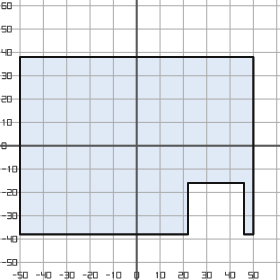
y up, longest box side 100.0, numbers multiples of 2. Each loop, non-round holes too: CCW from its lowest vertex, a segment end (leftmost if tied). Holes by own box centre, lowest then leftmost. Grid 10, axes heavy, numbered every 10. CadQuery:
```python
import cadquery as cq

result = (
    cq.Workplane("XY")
    .moveTo(-50.0, -38.0)
    .lineTo(22.0, -38.0)
    .lineTo(22.0, -16.0)
    .lineTo(46.0, -16.0)
    .lineTo(46.0, -38.0)
    .lineTo(50.0, -38.0)
    .lineTo(50.0, 38.0)
    .lineTo(-50.0, 38.0)
    .close()
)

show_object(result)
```